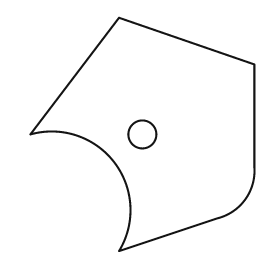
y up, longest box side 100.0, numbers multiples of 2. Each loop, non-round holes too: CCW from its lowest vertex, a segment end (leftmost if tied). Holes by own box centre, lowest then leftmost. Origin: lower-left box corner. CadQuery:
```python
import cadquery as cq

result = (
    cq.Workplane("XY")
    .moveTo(38.0, 0.0)
    .lineTo(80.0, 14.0)
    .threePointArc((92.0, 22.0), (96.0, 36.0))
    .lineTo(96.0, 80.0)
    .lineTo(38.0, 100.0)
    .lineTo(0.0, 50.0)
    .threePointArc((36.0, 38.0), (38.0, 0.0))
    .close()
    .moveTo(48.0, 50.0)
    .circle(6.0)
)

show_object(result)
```